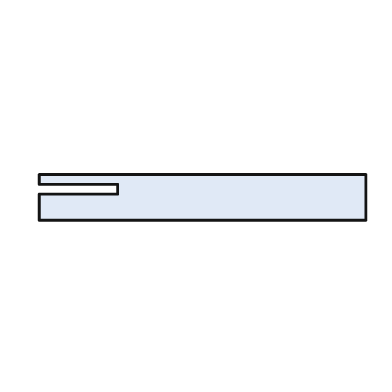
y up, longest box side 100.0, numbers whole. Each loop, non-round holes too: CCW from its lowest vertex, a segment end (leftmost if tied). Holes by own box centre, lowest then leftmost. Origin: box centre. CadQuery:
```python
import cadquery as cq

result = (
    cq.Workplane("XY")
    .moveTo(-50.0, -7.0)
    .lineTo(50.0, -7.0)
    .lineTo(50.0, 7.0)
    .lineTo(-50.0, 7.0)
    .lineTo(-50.0, 4.0)
    .lineTo(-26.0, 4.0)
    .lineTo(-26.0, 1.0)
    .lineTo(-50.0, 1.0)
    .close()
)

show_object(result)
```